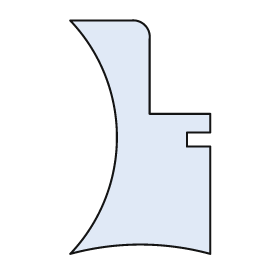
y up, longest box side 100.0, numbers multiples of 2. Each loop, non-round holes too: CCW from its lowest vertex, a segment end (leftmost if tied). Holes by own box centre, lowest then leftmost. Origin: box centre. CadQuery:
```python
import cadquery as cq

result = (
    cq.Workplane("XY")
    .moveTo(-30.0, -50.0)
    .threePointArc((0.0, -46.0), (30.0, -50.0))
    .lineTo(30.0, -4.0)
    .lineTo(20.0, -4.0)
    .lineTo(20.0, 2.0)
    .lineTo(30.0, 2.0)
    .lineTo(30.0, 10.0)
    .lineTo(4.0, 10.0)
    .lineTo(4.0, 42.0)
    .threePointArc((2.0, 48.0), (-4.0, 50.0))
    .lineTo(-30.0, 50.0)
    .threePointArc((-10.0, 0.0), (-30.0, -50.0))
    .close()
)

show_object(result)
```